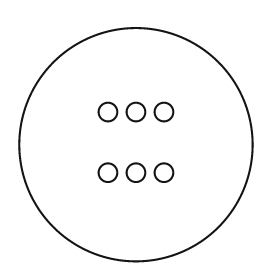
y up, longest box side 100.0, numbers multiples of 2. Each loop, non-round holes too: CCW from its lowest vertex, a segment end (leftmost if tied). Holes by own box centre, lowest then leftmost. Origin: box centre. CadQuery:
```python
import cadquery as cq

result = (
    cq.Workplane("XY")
    .moveTo(0.0, 0.0)
    .circle(50.0)
    .moveTo(-12.0, -12.0)
    .circle(4.0)
    .moveTo(0.0, -12.0)
    .circle(4.0)
    .moveTo(12.0, -12.0)
    .circle(4.0)
    .moveTo(-12.0, 14.0)
    .circle(4.0)
    .moveTo(0.0, 14.0)
    .circle(4.0)
    .moveTo(12.0, 14.0)
    .circle(4.0)
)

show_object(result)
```